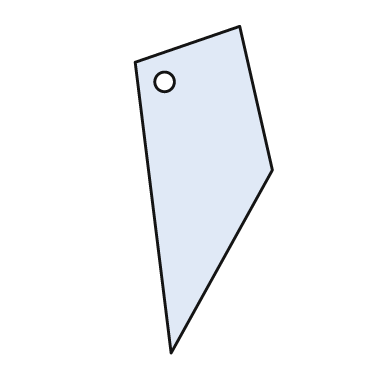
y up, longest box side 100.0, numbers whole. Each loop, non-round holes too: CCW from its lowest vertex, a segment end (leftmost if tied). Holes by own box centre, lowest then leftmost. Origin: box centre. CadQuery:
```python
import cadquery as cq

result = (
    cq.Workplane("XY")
    .moveTo(-10.0, -50.0)
    .lineTo(21.0, 6.0)
    .lineTo(11.0, 50.0)
    .lineTo(-21.0, 39.0)
    .close()
    .moveTo(-12.0, 33.0)
    .circle(3.0)
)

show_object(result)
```